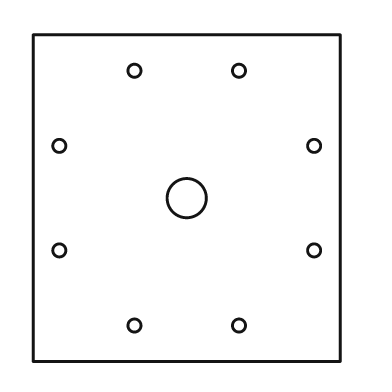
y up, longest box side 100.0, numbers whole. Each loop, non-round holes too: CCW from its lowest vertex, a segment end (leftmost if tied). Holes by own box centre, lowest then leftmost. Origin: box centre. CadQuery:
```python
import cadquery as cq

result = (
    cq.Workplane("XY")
    .moveTo(-47.0, -50.0)
    .lineTo(47.0, -50.0)
    .lineTo(47.0, 50.0)
    .lineTo(-47.0, 50.0)
    .close()
    .moveTo(-16.0, -39.0)
    .circle(2.0)
    .moveTo(16.0, -39.0)
    .circle(2.0)
    .moveTo(-39.0, -16.0)
    .circle(2.0)
    .moveTo(39.0, -16.0)
    .circle(2.0)
    .moveTo(0.0, 0.0)
    .circle(6.0)
    .moveTo(-39.0, 16.0)
    .circle(2.0)
    .moveTo(39.0, 16.0)
    .circle(2.0)
    .moveTo(-16.0, 39.0)
    .circle(2.0)
    .moveTo(16.0, 39.0)
    .circle(2.0)
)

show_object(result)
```